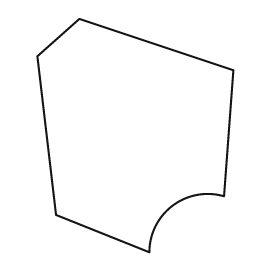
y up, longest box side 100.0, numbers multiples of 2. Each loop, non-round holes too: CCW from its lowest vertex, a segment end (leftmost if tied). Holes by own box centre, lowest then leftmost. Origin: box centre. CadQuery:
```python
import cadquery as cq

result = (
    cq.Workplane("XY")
    .moveTo(6.0, -50.0)
    .threePointArc((16.0, -30.0), (38.0, -26.0))
    .lineTo(42.0, 28.0)
    .lineTo(-24.0, 50.0)
    .lineTo(-42.0, 34.0)
    .lineTo(-34.0, -34.0)
    .close()
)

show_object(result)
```